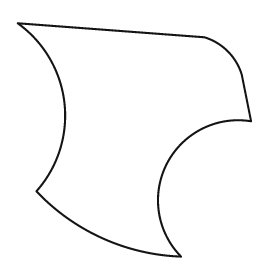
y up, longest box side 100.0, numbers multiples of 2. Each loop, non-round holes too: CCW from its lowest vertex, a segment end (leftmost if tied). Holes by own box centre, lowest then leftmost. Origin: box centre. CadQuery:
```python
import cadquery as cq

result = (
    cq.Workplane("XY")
    .moveTo(20.0, -50.0)
    .threePointArc((14.0, -10.0), (50.0, 8.0))
    .lineTo(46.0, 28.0)
    .threePointArc((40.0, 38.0), (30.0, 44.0))
    .lineTo(-50.0, 50.0)
    .threePointArc((-30.0, 16.0), (-42.0, -22.0))
    .threePointArc((-14.0, -42.0), (20.0, -50.0))
    .close()
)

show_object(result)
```